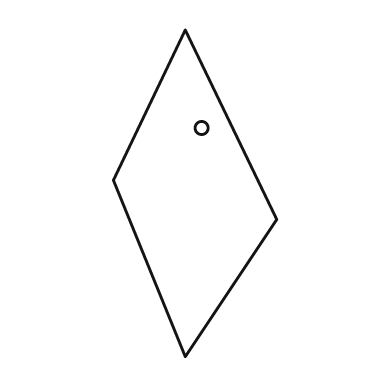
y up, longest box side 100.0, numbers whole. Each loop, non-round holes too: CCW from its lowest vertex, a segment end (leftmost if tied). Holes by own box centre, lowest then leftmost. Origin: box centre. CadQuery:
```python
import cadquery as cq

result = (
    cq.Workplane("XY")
    .moveTo(-3.0, -50.0)
    .lineTo(25.0, -8.0)
    .lineTo(-3.0, 50.0)
    .lineTo(-25.0, 4.0)
    .close()
    .moveTo(2.0, 20.0)
    .circle(2.0)
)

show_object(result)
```